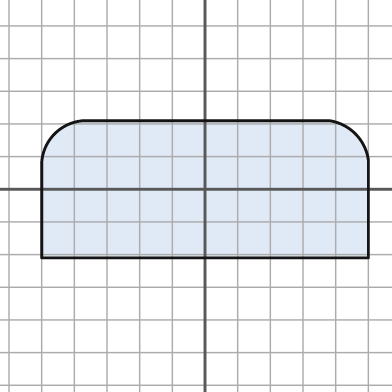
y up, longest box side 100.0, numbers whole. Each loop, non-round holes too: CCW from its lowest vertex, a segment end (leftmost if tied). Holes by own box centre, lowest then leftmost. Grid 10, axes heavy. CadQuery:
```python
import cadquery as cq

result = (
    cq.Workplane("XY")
    .moveTo(-50.0, -21.0)
    .lineTo(50.0, -21.0)
    .lineTo(50.0, 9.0)
    .threePointArc((46.0, 17.0), (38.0, 21.0))
    .lineTo(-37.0, 21.0)
    .threePointArc((-46.0, 17.0), (-50.0, 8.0))
    .close()
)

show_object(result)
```